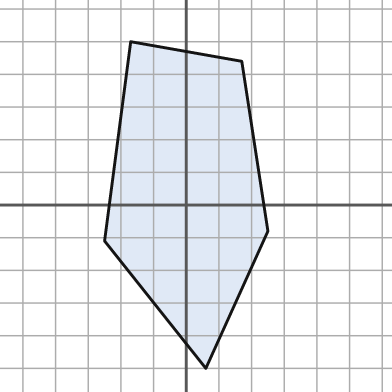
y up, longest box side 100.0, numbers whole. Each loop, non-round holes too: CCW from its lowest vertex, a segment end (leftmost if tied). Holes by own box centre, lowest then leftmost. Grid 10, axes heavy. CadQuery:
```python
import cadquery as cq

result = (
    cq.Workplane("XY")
    .moveTo(6.0, -50.0)
    .lineTo(25.0, -8.0)
    .lineTo(17.0, 44.0)
    .lineTo(-17.0, 50.0)
    .lineTo(-25.0, -11.0)
    .close()
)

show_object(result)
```